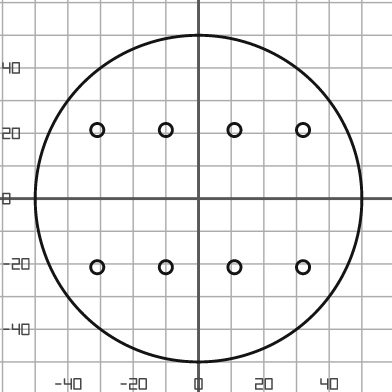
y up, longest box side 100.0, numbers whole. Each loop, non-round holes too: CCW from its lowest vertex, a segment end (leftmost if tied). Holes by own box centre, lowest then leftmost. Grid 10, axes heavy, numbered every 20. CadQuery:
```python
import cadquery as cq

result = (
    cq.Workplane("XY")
    .moveTo(0.0, 0.0)
    .circle(50.0)
    .moveTo(-31.0, -21.0)
    .circle(2.0)
    .moveTo(-10.0, -21.0)
    .circle(2.0)
    .moveTo(11.0, -21.0)
    .circle(2.0)
    .moveTo(32.0, -21.0)
    .circle(2.0)
    .moveTo(-31.0, 21.0)
    .circle(2.0)
    .moveTo(-10.0, 21.0)
    .circle(2.0)
    .moveTo(11.0, 21.0)
    .circle(2.0)
    .moveTo(32.0, 21.0)
    .circle(2.0)
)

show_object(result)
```